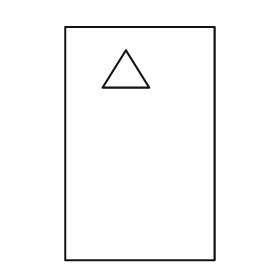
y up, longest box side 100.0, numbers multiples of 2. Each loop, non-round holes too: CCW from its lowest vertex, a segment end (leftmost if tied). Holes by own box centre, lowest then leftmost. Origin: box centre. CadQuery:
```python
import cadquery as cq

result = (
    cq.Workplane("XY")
    .moveTo(-32.0, -50.0)
    .lineTo(32.0, -50.0)
    .lineTo(32.0, 50.0)
    .lineTo(-32.0, 50.0)
    .close()
    .moveTo(-16.0, 24.0)
    .lineTo(4.0, 24.0)
    .lineTo(-6.0, 40.0)
    .close()
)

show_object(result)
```